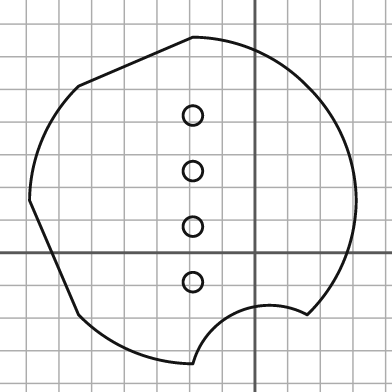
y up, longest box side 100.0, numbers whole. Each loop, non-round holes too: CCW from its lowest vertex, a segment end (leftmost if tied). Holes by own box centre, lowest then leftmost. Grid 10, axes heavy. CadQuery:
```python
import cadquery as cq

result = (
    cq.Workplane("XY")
    .moveTo(-19.0, -34.0)
    .threePointArc((-5.0, -18.0), (16.0, -19.0))
    .threePointArc((27.0, -3.0), (31.0, 16.0))
    .threePointArc((27.0, 35.0), (16.0, 51.0))
    .threePointArc((0.0, 62.0), (-19.0, 66.0))
    .lineTo(-54.0, 51.0)
    .threePointArc((-65.0, 35.0), (-69.0, 16.0))
    .lineTo(-54.0, -19.0)
    .threePointArc((-38.0, -30.0), (-19.0, -34.0))
    .close()
    .moveTo(-19.0, -9.0)
    .circle(3.0)
    .moveTo(-19.0, 8.0)
    .circle(3.0)
    .moveTo(-19.0, 25.0)
    .circle(3.0)
    .moveTo(-19.0, 42.0)
    .circle(3.0)
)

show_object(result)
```